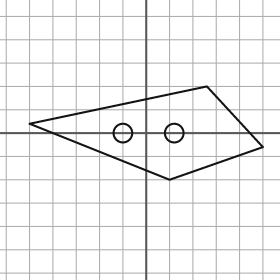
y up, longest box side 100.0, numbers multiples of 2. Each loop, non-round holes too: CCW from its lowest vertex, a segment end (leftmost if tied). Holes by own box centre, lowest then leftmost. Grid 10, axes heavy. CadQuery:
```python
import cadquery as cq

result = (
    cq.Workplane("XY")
    .moveTo(10.0, -20.0)
    .lineTo(50.0, -6.0)
    .lineTo(26.0, 20.0)
    .lineTo(-50.0, 4.0)
    .close()
    .moveTo(-10.0, 0.0)
    .circle(4.0)
    .moveTo(12.0, 0.0)
    .circle(4.0)
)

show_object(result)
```